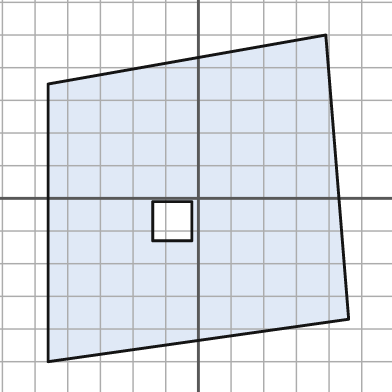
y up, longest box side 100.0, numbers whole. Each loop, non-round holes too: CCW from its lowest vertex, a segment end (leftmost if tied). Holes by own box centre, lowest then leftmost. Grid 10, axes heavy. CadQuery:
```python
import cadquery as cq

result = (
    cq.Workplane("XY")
    .moveTo(-46.0, -50.0)
    .lineTo(46.0, -37.0)
    .lineTo(39.0, 50.0)
    .lineTo(-46.0, 35.0)
    .close()
    .moveTo(-14.0, -13.0)
    .lineTo(-2.0, -13.0)
    .lineTo(-2.0, -1.0)
    .lineTo(-14.0, -1.0)
    .close()
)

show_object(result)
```